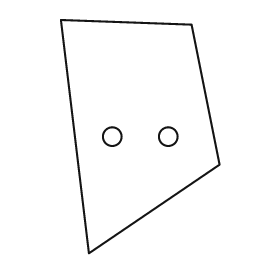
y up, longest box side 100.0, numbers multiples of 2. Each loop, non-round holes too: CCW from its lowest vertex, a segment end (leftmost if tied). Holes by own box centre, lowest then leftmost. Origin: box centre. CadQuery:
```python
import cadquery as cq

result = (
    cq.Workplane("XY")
    .moveTo(-22.0, -50.0)
    .lineTo(34.0, -12.0)
    .lineTo(22.0, 48.0)
    .lineTo(-34.0, 50.0)
    .close()
    .moveTo(-12.0, 0.0)
    .circle(4.0)
    .moveTo(12.0, 0.0)
    .circle(4.0)
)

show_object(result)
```